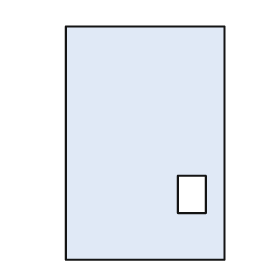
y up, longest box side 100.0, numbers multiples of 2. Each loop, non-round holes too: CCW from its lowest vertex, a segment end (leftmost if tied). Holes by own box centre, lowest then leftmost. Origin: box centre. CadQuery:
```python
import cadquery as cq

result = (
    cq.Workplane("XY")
    .moveTo(-34.0, -50.0)
    .lineTo(34.0, -50.0)
    .lineTo(34.0, 50.0)
    .lineTo(-34.0, 50.0)
    .close()
    .moveTo(14.0, -30.0)
    .lineTo(26.0, -30.0)
    .lineTo(26.0, -14.0)
    .lineTo(14.0, -14.0)
    .close()
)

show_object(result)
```